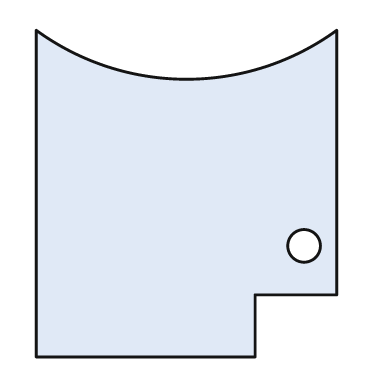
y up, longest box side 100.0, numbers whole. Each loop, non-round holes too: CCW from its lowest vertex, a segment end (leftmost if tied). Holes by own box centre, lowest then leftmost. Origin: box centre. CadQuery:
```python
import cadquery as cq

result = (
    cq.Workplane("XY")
    .moveTo(-46.0, -50.0)
    .lineTo(21.0, -50.0)
    .lineTo(21.0, -31.0)
    .lineTo(46.0, -31.0)
    .lineTo(46.0, 50.0)
    .threePointArc((0.0, 35.0), (-46.0, 50.0))
    .close()
    .moveTo(36.0, -16.0)
    .circle(5.0)
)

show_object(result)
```